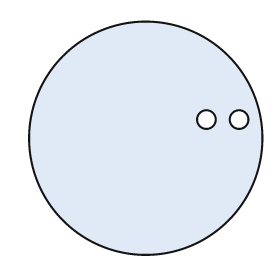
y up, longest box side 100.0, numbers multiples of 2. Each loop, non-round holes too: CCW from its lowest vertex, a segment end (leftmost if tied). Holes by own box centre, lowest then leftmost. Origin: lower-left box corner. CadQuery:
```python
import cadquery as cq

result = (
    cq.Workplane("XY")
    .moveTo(50.0, 50.0)
    .circle(50.0)
    .moveTo(76.0, 58.0)
    .circle(4.0)
    .moveTo(90.0, 58.0)
    .circle(4.0)
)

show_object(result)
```